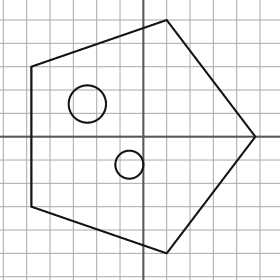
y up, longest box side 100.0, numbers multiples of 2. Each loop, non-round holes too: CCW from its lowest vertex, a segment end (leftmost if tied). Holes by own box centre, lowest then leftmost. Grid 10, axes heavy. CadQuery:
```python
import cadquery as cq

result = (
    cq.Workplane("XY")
    .moveTo(10.0, -50.0)
    .lineTo(48.0, 0.0)
    .lineTo(10.0, 50.0)
    .lineTo(-48.0, 30.0)
    .lineTo(-48.0, -30.0)
    .close()
    .moveTo(-6.0, -12.0)
    .circle(6.0)
    .moveTo(-24.0, 14.0)
    .circle(8.0)
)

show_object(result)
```